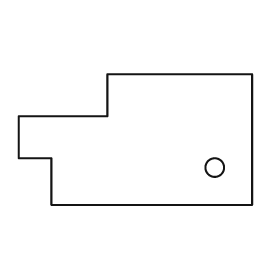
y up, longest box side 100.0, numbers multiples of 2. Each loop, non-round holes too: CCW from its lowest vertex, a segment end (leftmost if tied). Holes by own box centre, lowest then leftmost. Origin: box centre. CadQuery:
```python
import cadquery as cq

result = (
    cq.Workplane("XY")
    .moveTo(-36.0, -28.0)
    .lineTo(50.0, -28.0)
    .lineTo(50.0, 28.0)
    .lineTo(-12.0, 28.0)
    .lineTo(-12.0, 10.0)
    .lineTo(-50.0, 10.0)
    .lineTo(-50.0, -8.0)
    .lineTo(-36.0, -8.0)
    .close()
    .moveTo(34.0, -12.0)
    .circle(4.0)
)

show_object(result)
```